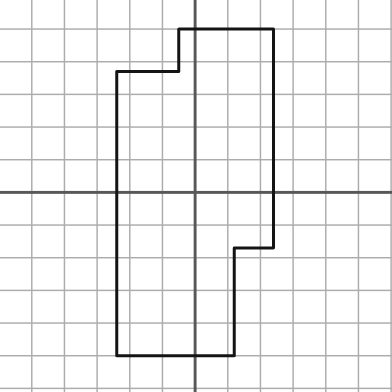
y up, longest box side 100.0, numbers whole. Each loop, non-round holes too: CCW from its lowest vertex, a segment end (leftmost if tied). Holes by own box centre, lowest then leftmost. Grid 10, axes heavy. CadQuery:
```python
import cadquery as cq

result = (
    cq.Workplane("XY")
    .moveTo(-24.0, -50.0)
    .lineTo(12.0, -50.0)
    .lineTo(12.0, -17.0)
    .lineTo(24.0, -17.0)
    .lineTo(24.0, 50.0)
    .lineTo(-5.0, 50.0)
    .lineTo(-5.0, 37.0)
    .lineTo(-24.0, 37.0)
    .close()
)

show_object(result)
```